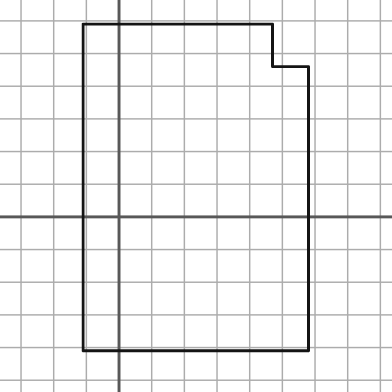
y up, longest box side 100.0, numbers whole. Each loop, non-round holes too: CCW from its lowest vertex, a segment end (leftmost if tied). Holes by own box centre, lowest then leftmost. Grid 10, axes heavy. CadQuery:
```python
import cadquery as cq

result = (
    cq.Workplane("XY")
    .moveTo(-11.0, -41.0)
    .lineTo(58.0, -41.0)
    .lineTo(58.0, 46.0)
    .lineTo(47.0, 46.0)
    .lineTo(47.0, 59.0)
    .lineTo(-11.0, 59.0)
    .close()
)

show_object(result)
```